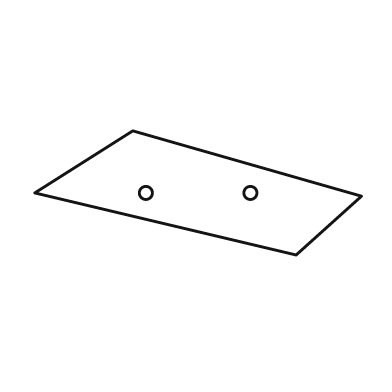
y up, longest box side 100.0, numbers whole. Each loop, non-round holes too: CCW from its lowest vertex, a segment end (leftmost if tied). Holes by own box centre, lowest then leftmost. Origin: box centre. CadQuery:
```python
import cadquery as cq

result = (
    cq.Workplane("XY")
    .moveTo(30.0, -19.0)
    .lineTo(50.0, -1.0)
    .lineTo(-20.0, 19.0)
    .lineTo(-50.0, 0.0)
    .close()
    .moveTo(-16.0, 0.0)
    .circle(2.0)
    .moveTo(16.0, 0.0)
    .circle(2.0)
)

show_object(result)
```